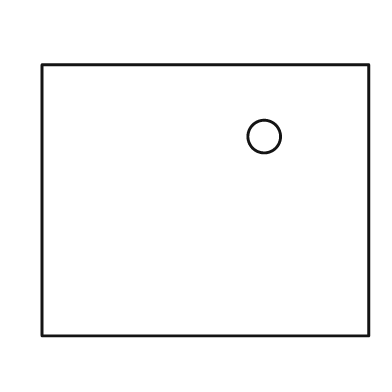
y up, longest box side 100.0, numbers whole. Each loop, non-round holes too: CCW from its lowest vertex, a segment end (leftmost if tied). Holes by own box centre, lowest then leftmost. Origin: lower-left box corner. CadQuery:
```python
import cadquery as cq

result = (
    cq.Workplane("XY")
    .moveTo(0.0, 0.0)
    .lineTo(100.0, 0.0)
    .lineTo(100.0, 83.0)
    .lineTo(0.0, 83.0)
    .close()
    .moveTo(68.0, 61.0)
    .circle(5.0)
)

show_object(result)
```